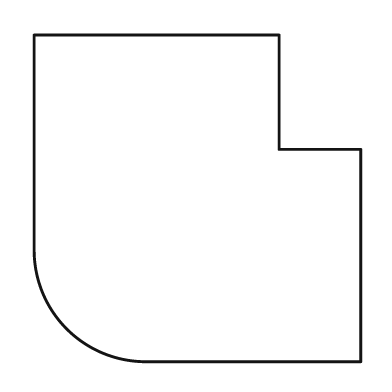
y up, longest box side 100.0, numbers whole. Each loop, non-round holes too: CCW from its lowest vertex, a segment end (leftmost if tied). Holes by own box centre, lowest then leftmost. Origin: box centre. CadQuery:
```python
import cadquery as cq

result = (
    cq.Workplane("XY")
    .moveTo(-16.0, -50.0)
    .lineTo(50.0, -50.0)
    .lineTo(50.0, 15.0)
    .lineTo(25.0, 15.0)
    .lineTo(25.0, 50.0)
    .lineTo(-50.0, 50.0)
    .lineTo(-50.0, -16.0)
    .threePointArc((-40.0, -40.0), (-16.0, -50.0))
    .close()
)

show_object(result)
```